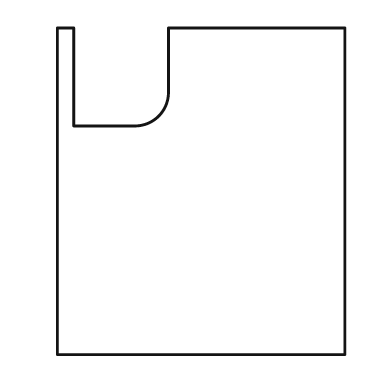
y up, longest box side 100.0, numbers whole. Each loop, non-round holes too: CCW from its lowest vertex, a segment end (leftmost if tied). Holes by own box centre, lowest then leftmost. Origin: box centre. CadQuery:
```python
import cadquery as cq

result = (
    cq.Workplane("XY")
    .moveTo(-44.0, -50.0)
    .lineTo(44.0, -50.0)
    .lineTo(44.0, 50.0)
    .lineTo(-10.0, 50.0)
    .lineTo(-10.0, 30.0)
    .threePointArc((-13.0, 23.0), (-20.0, 20.0))
    .lineTo(-39.0, 20.0)
    .lineTo(-39.0, 50.0)
    .lineTo(-44.0, 50.0)
    .close()
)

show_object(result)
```